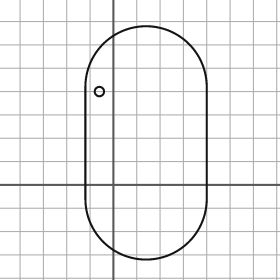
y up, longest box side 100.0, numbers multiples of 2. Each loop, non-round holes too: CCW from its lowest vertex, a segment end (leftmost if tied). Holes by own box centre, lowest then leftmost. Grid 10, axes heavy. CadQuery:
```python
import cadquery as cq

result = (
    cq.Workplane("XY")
    .moveTo(-12.0, -6.0)
    .threePointArc((14.0, -32.0), (40.0, -6.0))
    .lineTo(40.0, 42.0)
    .threePointArc((14.0, 68.0), (-12.0, 42.0))
    .close()
    .moveTo(-6.0, 40.0)
    .circle(2.0)
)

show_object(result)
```